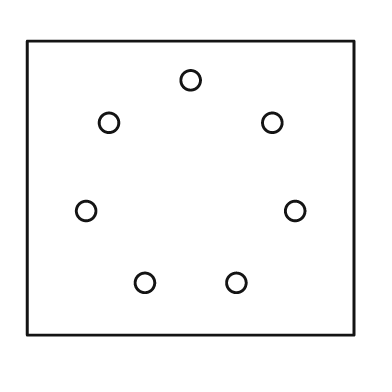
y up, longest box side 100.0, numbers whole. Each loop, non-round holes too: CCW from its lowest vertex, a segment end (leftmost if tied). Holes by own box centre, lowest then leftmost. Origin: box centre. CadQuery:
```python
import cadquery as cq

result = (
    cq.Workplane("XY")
    .moveTo(-50.0, -45.0)
    .lineTo(50.0, -45.0)
    .lineTo(50.0, 45.0)
    .lineTo(-50.0, 45.0)
    .close()
    .moveTo(-14.0, -29.0)
    .circle(3.0)
    .moveTo(14.0, -29.0)
    .circle(3.0)
    .moveTo(-32.0, -7.0)
    .circle(3.0)
    .moveTo(32.0, -7.0)
    .circle(3.0)
    .moveTo(-25.0, 20.0)
    .circle(3.0)
    .moveTo(25.0, 20.0)
    .circle(3.0)
    .moveTo(0.0, 33.0)
    .circle(3.0)
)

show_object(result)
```